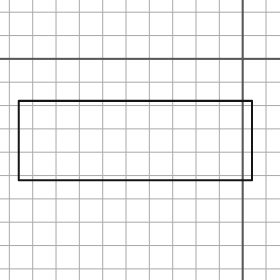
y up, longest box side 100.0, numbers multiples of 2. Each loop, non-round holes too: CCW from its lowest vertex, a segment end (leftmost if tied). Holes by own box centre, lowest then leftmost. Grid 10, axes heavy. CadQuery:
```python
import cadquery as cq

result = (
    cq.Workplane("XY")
    .moveTo(-96.0, -52.0)
    .lineTo(4.0, -52.0)
    .lineTo(4.0, -18.0)
    .lineTo(-96.0, -18.0)
    .close()
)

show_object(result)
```